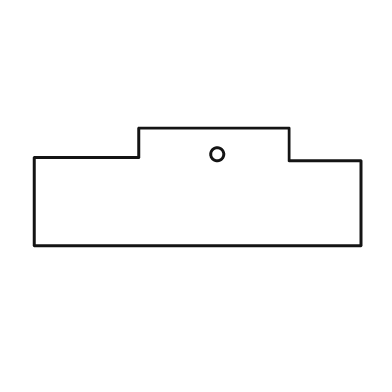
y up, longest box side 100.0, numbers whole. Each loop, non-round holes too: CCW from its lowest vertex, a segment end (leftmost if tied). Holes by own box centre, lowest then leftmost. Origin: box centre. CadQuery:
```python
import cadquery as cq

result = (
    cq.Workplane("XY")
    .moveTo(-50.0, -18.0)
    .lineTo(50.0, -18.0)
    .lineTo(50.0, 8.0)
    .lineTo(28.0, 8.0)
    .lineTo(28.0, 18.0)
    .lineTo(-18.0, 18.0)
    .lineTo(-18.0, 9.0)
    .lineTo(-50.0, 9.0)
    .close()
    .moveTo(6.0, 10.0)
    .circle(2.0)
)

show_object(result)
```